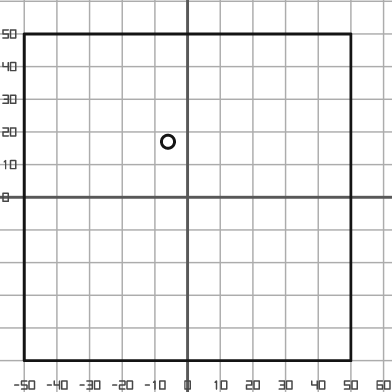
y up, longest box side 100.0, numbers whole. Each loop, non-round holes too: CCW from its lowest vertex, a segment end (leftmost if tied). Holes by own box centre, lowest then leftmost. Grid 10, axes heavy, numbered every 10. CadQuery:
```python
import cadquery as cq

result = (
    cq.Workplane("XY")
    .moveTo(-50.0, -50.0)
    .lineTo(50.0, -50.0)
    .lineTo(50.0, 50.0)
    .lineTo(-50.0, 50.0)
    .close()
    .moveTo(-6.0, 17.0)
    .circle(2.0)
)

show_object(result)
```